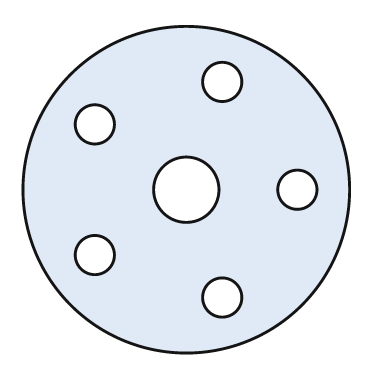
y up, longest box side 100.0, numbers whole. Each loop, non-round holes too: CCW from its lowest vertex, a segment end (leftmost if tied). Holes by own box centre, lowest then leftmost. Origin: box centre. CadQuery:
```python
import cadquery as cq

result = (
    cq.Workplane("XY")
    .moveTo(0.0, 0.0)
    .circle(50.0)
    .moveTo(11.0, -33.0)
    .circle(6.0)
    .moveTo(-28.0, -20.0)
    .circle(6.0)
    .moveTo(0.0, 0.0)
    .circle(10.0)
    .moveTo(34.0, 0.0)
    .circle(6.0)
    .moveTo(-28.0, 20.0)
    .circle(6.0)
    .moveTo(11.0, 33.0)
    .circle(6.0)
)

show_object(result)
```